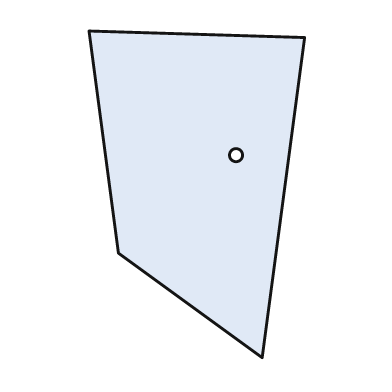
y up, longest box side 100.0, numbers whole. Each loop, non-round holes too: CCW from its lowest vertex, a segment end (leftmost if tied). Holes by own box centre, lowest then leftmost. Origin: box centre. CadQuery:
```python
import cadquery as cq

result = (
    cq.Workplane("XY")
    .moveTo(20.0, -50.0)
    .lineTo(33.0, 48.0)
    .lineTo(-33.0, 50.0)
    .lineTo(-24.0, -18.0)
    .close()
    .moveTo(12.0, 12.0)
    .circle(2.0)
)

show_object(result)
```